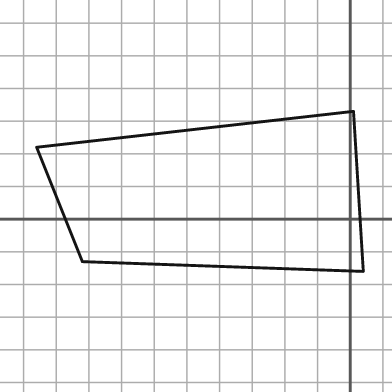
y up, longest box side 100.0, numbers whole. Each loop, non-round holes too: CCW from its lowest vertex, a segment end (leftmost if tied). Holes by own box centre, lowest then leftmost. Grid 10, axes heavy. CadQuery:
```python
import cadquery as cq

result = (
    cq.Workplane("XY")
    .moveTo(4.0, -16.0)
    .lineTo(1.0, 33.0)
    .lineTo(-96.0, 22.0)
    .lineTo(-82.0, -13.0)
    .close()
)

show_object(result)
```